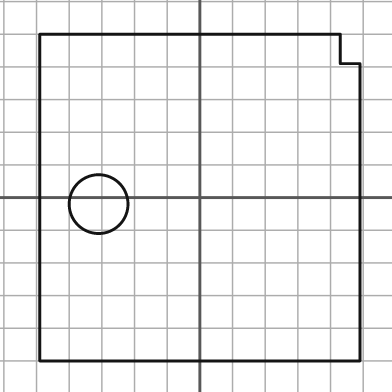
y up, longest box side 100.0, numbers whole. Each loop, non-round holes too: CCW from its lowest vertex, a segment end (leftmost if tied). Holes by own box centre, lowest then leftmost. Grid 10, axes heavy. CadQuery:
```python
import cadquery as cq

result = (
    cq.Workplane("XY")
    .moveTo(-49.0, -50.0)
    .lineTo(49.0, -50.0)
    .lineTo(49.0, 41.0)
    .lineTo(43.0, 41.0)
    .lineTo(43.0, 50.0)
    .lineTo(-49.0, 50.0)
    .close()
    .moveTo(-31.0, -2.0)
    .circle(9.0)
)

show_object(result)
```